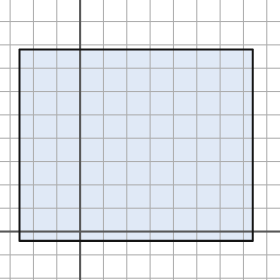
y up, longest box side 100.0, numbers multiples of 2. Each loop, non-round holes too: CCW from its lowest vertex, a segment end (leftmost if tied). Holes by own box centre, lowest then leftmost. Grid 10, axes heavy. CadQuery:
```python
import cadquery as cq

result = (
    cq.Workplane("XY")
    .moveTo(-26.0, -4.0)
    .lineTo(74.0, -4.0)
    .lineTo(74.0, 78.0)
    .lineTo(-26.0, 78.0)
    .close()
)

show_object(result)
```